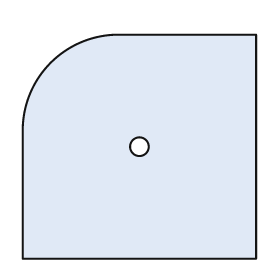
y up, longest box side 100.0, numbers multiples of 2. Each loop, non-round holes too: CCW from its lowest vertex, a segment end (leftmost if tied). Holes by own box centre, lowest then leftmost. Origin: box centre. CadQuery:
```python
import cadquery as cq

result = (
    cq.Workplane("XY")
    .moveTo(-50.0, -48.0)
    .lineTo(50.0, -48.0)
    .lineTo(50.0, 48.0)
    .lineTo(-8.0, 48.0)
    .threePointArc((-38.0, 36.0), (-50.0, 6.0))
    .close()
    .moveTo(0.0, 0.0)
    .circle(4.0)
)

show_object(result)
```